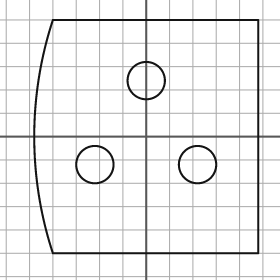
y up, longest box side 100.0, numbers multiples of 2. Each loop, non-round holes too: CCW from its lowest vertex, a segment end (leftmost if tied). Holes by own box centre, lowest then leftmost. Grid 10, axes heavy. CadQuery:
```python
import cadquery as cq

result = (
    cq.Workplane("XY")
    .moveTo(-40.0, -50.0)
    .lineTo(48.0, -50.0)
    .lineTo(48.0, 50.0)
    .lineTo(-40.0, 50.0)
    .threePointArc((-48.0, 0.0), (-40.0, -50.0))
    .close()
    .moveTo(-22.0, -12.0)
    .circle(8.0)
    .moveTo(22.0, -12.0)
    .circle(8.0)
    .moveTo(0.0, 24.0)
    .circle(8.0)
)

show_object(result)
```